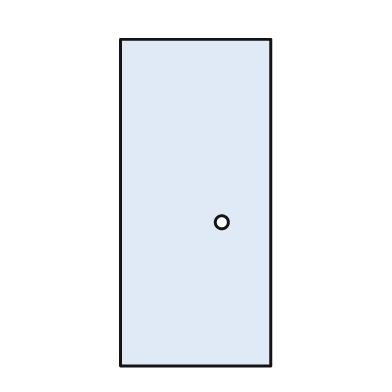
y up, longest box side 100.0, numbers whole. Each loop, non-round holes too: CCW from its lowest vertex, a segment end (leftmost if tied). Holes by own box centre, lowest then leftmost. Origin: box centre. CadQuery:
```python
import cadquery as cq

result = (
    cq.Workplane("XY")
    .moveTo(-23.0, -50.0)
    .lineTo(23.0, -50.0)
    .lineTo(23.0, 50.0)
    .lineTo(-23.0, 50.0)
    .close()
    .moveTo(8.0, -6.0)
    .circle(2.0)
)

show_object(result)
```